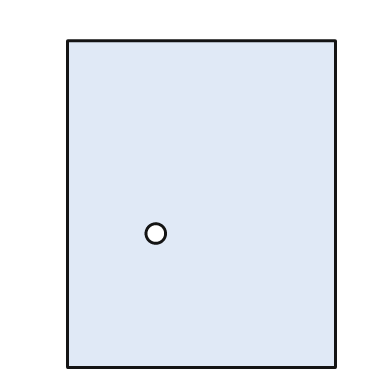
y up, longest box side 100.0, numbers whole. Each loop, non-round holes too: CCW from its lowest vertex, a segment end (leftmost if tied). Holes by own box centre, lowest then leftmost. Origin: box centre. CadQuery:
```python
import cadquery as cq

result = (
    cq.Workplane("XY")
    .moveTo(-41.0, -50.0)
    .lineTo(41.0, -50.0)
    .lineTo(41.0, 50.0)
    .lineTo(-41.0, 50.0)
    .close()
    .moveTo(-14.0, -9.0)
    .circle(3.0)
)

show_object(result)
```